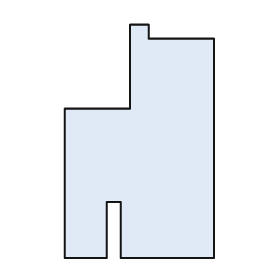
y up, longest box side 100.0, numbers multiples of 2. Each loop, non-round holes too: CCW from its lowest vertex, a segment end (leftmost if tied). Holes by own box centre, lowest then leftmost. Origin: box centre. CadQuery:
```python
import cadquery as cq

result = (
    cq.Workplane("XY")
    .moveTo(-32.0, -50.0)
    .lineTo(-14.0, -50.0)
    .lineTo(-14.0, -26.0)
    .lineTo(-8.0, -26.0)
    .lineTo(-8.0, -50.0)
    .lineTo(32.0, -50.0)
    .lineTo(32.0, 44.0)
    .lineTo(4.0, 44.0)
    .lineTo(4.0, 50.0)
    .lineTo(-4.0, 50.0)
    .lineTo(-4.0, 14.0)
    .lineTo(-32.0, 14.0)
    .close()
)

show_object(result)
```